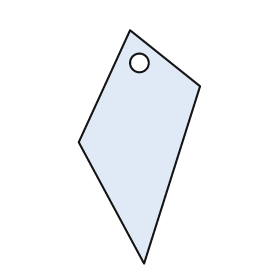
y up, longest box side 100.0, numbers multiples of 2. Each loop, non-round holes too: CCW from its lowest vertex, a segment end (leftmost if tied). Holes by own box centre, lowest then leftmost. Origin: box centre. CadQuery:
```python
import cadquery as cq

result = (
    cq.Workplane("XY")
    .moveTo(2.0, -50.0)
    .lineTo(26.0, 26.0)
    .lineTo(-4.0, 50.0)
    .lineTo(-26.0, 2.0)
    .close()
    .moveTo(0.0, 36.0)
    .circle(4.0)
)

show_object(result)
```